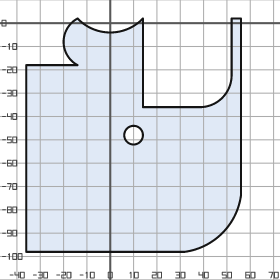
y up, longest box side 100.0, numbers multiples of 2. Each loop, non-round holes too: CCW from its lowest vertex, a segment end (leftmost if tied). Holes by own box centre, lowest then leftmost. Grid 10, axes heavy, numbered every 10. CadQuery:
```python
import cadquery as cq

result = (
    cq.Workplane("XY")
    .moveTo(-36.0, -98.0)
    .lineTo(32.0, -98.0)
    .threePointArc((48.0, -90.0), (56.0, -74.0))
    .lineTo(56.0, 2.0)
    .lineTo(52.0, 2.0)
    .lineTo(52.0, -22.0)
    .threePointArc((48.0, -32.0), (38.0, -36.0))
    .lineTo(14.0, -36.0)
    .lineTo(14.0, 2.0)
    .threePointArc((0.0, -4.0), (-14.0, 2.0))
    .threePointArc((-20.0, -8.0), (-14.0, -18.0))
    .lineTo(-36.0, -18.0)
    .close()
    .moveTo(10.0, -48.0)
    .circle(4.0)
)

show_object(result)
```